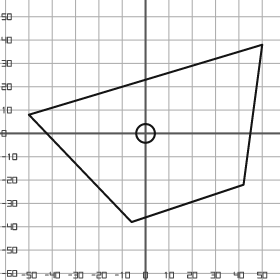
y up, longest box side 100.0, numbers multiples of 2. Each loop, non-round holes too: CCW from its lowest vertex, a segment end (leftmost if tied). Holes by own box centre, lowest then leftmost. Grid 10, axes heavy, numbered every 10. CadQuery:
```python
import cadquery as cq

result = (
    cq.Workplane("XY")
    .moveTo(-6.0, -38.0)
    .lineTo(42.0, -22.0)
    .lineTo(50.0, 38.0)
    .lineTo(-50.0, 8.0)
    .close()
    .moveTo(0.0, 0.0)
    .circle(4.0)
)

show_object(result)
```